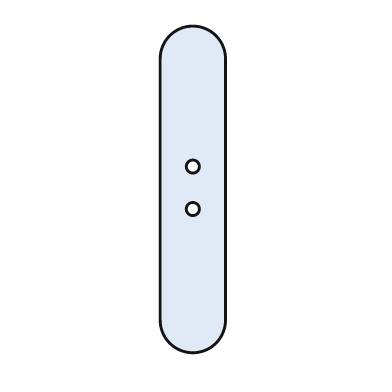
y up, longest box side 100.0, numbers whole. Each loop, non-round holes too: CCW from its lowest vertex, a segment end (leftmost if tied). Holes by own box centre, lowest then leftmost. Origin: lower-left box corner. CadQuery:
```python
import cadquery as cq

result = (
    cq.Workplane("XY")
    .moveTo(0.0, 10.0)
    .threePointArc((10.0, 0.0), (20.0, 10.0))
    .lineTo(20.0, 90.0)
    .threePointArc((10.0, 100.0), (0.0, 90.0))
    .close()
    .moveTo(10.0, 44.0)
    .circle(2.0)
    .moveTo(10.0, 57.0)
    .circle(2.0)
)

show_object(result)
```